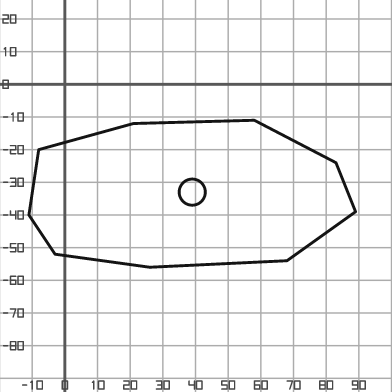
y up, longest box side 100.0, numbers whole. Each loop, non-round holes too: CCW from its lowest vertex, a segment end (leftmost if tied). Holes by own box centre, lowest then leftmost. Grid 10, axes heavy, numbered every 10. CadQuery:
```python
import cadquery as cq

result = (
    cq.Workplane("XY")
    .moveTo(26.0, -56.0)
    .lineTo(68.0, -54.0)
    .lineTo(89.0, -39.0)
    .lineTo(83.0, -24.0)
    .lineTo(58.0, -11.0)
    .lineTo(21.0, -12.0)
    .lineTo(-8.0, -20.0)
    .lineTo(-11.0, -40.0)
    .lineTo(-3.0, -52.0)
    .close()
    .moveTo(39.0, -33.0)
    .circle(4.0)
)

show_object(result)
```